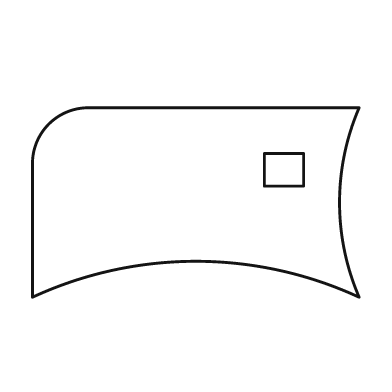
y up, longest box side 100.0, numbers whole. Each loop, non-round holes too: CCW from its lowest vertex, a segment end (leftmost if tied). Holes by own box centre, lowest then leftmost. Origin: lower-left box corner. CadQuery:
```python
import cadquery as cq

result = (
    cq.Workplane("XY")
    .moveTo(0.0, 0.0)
    .threePointArc((50.0, 11.0), (100.0, 0.0))
    .threePointArc((94.0, 29.0), (100.0, 58.0))
    .lineTo(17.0, 58.0)
    .threePointArc((5.0, 53.0), (0.0, 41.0))
    .close()
    .moveTo(71.0, 34.0)
    .lineTo(83.0, 34.0)
    .lineTo(83.0, 44.0)
    .lineTo(71.0, 44.0)
    .close()
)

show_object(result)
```